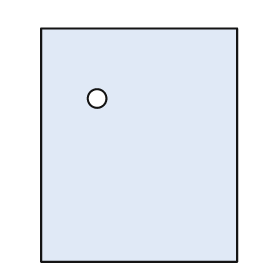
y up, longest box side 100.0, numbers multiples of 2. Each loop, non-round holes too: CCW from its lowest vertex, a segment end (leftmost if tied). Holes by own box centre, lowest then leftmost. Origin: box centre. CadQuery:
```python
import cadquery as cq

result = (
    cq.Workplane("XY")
    .moveTo(-42.0, -50.0)
    .lineTo(42.0, -50.0)
    .lineTo(42.0, 50.0)
    .lineTo(-42.0, 50.0)
    .close()
    .moveTo(-18.0, 20.0)
    .circle(4.0)
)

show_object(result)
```